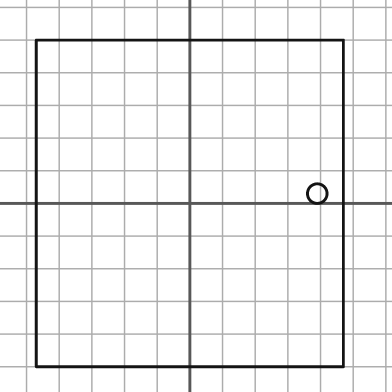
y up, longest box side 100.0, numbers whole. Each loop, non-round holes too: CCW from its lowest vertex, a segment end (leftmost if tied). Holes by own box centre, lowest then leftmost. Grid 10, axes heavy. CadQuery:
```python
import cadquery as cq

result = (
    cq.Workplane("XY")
    .moveTo(-47.0, -50.0)
    .lineTo(47.0, -50.0)
    .lineTo(47.0, 50.0)
    .lineTo(-47.0, 50.0)
    .close()
    .moveTo(39.0, 3.0)
    .circle(3.0)
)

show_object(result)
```